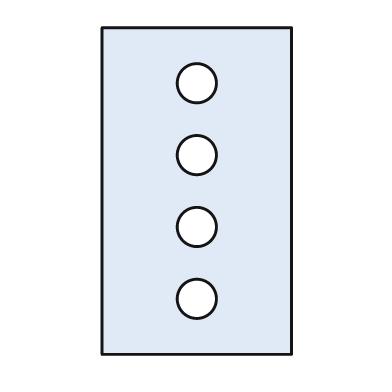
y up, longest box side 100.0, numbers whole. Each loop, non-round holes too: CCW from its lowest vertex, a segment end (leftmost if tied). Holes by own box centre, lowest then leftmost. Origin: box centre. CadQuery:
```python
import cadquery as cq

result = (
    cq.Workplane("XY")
    .moveTo(-29.0, -50.0)
    .lineTo(29.0, -50.0)
    .lineTo(29.0, 50.0)
    .lineTo(-29.0, 50.0)
    .close()
    .moveTo(0.0, -33.0)
    .circle(6.0)
    .moveTo(0.0, -11.0)
    .circle(6.0)
    .moveTo(0.0, 11.0)
    .circle(6.0)
    .moveTo(0.0, 33.0)
    .circle(6.0)
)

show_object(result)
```